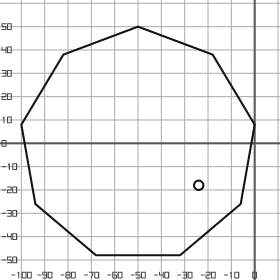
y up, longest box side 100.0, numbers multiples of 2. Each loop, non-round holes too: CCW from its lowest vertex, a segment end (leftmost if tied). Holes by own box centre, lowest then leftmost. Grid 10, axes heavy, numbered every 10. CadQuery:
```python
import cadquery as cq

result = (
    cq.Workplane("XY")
    .moveTo(-68.0, -48.0)
    .lineTo(-32.0, -48.0)
    .lineTo(-6.0, -26.0)
    .lineTo(0.0, 8.0)
    .lineTo(-18.0, 38.0)
    .lineTo(-50.0, 50.0)
    .lineTo(-82.0, 38.0)
    .lineTo(-100.0, 8.0)
    .lineTo(-94.0, -26.0)
    .close()
    .moveTo(-24.0, -18.0)
    .circle(2.0)
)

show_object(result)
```